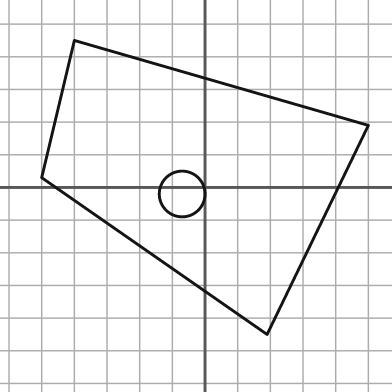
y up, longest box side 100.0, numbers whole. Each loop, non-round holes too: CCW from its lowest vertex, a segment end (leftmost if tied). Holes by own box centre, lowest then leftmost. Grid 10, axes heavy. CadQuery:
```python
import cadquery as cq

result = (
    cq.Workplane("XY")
    .moveTo(19.0, -45.0)
    .lineTo(50.0, 19.0)
    .lineTo(-40.0, 45.0)
    .lineTo(-50.0, 3.0)
    .close()
    .moveTo(-7.0, -2.0)
    .circle(7.0)
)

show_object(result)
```